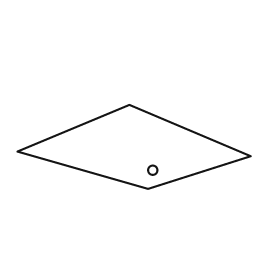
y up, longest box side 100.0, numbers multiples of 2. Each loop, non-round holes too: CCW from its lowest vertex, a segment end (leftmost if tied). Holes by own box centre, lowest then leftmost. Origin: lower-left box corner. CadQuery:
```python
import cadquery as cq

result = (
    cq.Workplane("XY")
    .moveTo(56.0, 0.0)
    .lineTo(100.0, 14.0)
    .lineTo(48.0, 36.0)
    .lineTo(0.0, 16.0)
    .close()
    .moveTo(58.0, 8.0)
    .circle(2.0)
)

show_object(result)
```